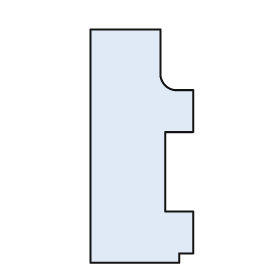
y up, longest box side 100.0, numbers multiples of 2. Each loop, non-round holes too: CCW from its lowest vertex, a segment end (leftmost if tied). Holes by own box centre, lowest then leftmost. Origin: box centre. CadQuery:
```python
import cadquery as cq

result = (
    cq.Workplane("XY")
    .moveTo(-22.0, -50.0)
    .lineTo(16.0, -50.0)
    .lineTo(16.0, -46.0)
    .lineTo(22.0, -46.0)
    .lineTo(22.0, -28.0)
    .lineTo(10.0, -28.0)
    .lineTo(10.0, 6.0)
    .lineTo(22.0, 6.0)
    .lineTo(22.0, 24.0)
    .lineTo(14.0, 24.0)
    .threePointArc((10.0, 26.0), (8.0, 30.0))
    .lineTo(8.0, 50.0)
    .lineTo(-22.0, 50.0)
    .close()
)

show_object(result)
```